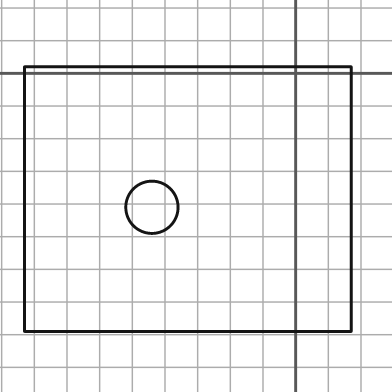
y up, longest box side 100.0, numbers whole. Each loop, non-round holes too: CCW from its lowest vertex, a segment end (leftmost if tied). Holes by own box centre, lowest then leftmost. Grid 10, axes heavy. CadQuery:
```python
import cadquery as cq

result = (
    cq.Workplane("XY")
    .moveTo(-83.0, -79.0)
    .lineTo(17.0, -79.0)
    .lineTo(17.0, 2.0)
    .lineTo(-83.0, 2.0)
    .close()
    .moveTo(-44.0, -41.0)
    .circle(8.0)
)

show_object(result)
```